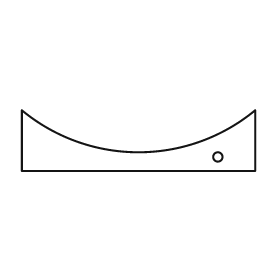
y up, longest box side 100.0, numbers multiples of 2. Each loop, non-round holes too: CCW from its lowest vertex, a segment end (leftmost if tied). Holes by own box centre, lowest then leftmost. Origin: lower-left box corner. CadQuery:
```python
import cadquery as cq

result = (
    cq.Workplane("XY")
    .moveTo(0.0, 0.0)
    .lineTo(100.0, 0.0)
    .lineTo(100.0, 26.0)
    .threePointArc((50.0, 8.0), (0.0, 26.0))
    .close()
    .moveTo(84.0, 6.0)
    .circle(2.0)
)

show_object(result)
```